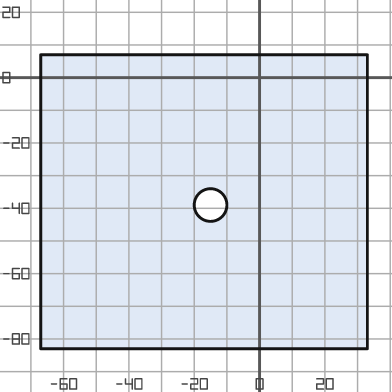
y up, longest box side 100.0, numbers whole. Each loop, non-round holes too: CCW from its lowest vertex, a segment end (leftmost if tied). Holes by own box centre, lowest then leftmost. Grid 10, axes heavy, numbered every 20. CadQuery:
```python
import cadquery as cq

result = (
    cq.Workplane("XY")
    .moveTo(-67.0, -83.0)
    .lineTo(33.0, -83.0)
    .lineTo(33.0, 7.0)
    .lineTo(-67.0, 7.0)
    .close()
    .moveTo(-15.0, -39.0)
    .circle(5.0)
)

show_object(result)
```